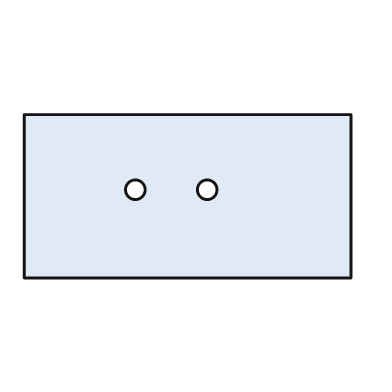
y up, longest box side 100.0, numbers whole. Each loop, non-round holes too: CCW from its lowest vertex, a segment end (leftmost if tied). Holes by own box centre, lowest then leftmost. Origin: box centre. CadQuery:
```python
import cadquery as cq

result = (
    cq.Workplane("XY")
    .moveTo(-50.0, -25.0)
    .lineTo(50.0, -25.0)
    .lineTo(50.0, 25.0)
    .lineTo(-50.0, 25.0)
    .close()
    .moveTo(-16.0, 2.0)
    .circle(3.0)
    .moveTo(6.0, 2.0)
    .circle(3.0)
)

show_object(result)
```